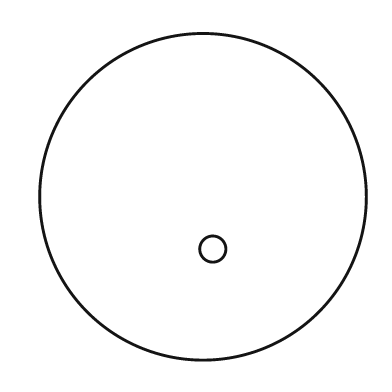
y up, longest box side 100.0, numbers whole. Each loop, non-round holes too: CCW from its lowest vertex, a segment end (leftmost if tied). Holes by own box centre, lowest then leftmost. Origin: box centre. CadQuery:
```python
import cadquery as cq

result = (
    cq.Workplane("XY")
    .moveTo(0.0, 0.0)
    .circle(50.0)
    .moveTo(3.0, -16.0)
    .circle(4.0)
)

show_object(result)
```